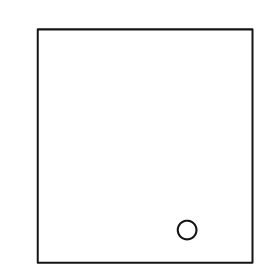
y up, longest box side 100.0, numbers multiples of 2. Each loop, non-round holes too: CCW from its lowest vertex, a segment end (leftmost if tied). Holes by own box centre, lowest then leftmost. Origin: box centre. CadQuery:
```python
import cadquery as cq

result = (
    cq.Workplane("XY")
    .moveTo(-46.0, -50.0)
    .lineTo(46.0, -50.0)
    .lineTo(46.0, 50.0)
    .lineTo(-46.0, 50.0)
    .close()
    .moveTo(18.0, -36.0)
    .circle(4.0)
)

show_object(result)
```